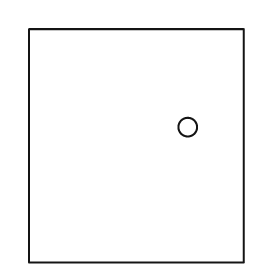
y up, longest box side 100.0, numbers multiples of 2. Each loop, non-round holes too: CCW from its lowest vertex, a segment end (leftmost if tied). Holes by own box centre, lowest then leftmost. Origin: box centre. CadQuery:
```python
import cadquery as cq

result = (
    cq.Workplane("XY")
    .moveTo(-46.0, -50.0)
    .lineTo(46.0, -50.0)
    .lineTo(46.0, 50.0)
    .lineTo(-46.0, 50.0)
    .close()
    .moveTo(22.0, 8.0)
    .circle(4.0)
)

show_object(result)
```